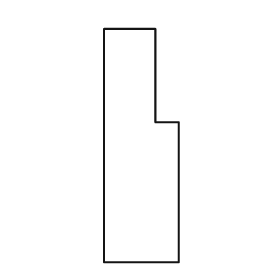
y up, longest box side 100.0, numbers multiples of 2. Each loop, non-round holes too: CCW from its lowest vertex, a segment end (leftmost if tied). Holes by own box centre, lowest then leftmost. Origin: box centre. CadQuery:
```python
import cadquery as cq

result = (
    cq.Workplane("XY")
    .moveTo(-16.0, -50.0)
    .lineTo(16.0, -50.0)
    .lineTo(16.0, 10.0)
    .lineTo(6.0, 10.0)
    .lineTo(6.0, 50.0)
    .lineTo(-16.0, 50.0)
    .close()
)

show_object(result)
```